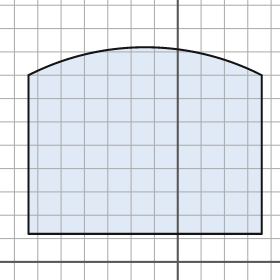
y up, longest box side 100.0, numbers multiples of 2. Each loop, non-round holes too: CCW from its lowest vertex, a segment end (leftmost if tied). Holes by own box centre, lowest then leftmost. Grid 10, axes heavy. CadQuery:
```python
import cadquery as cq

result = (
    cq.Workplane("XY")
    .moveTo(-64.0, 12.0)
    .lineTo(36.0, 12.0)
    .lineTo(36.0, 80.0)
    .threePointArc((-14.0, 92.0), (-64.0, 80.0))
    .close()
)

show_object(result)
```